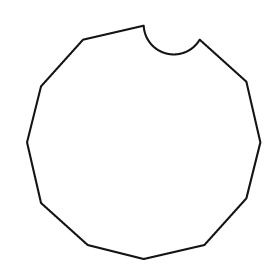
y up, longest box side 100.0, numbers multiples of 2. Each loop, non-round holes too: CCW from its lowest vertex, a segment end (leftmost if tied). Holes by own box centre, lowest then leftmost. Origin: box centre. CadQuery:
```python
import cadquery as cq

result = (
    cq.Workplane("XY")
    .moveTo(0.0, -50.0)
    .lineTo(26.0, -44.0)
    .lineTo(44.0, -24.0)
    .lineTo(50.0, 0.0)
    .lineTo(44.0, 26.0)
    .lineTo(24.0, 44.0)
    .threePointArc((10.0, 38.0), (0.0, 50.0))
    .lineTo(-26.0, 44.0)
    .lineTo(-44.0, 24.0)
    .lineTo(-50.0, 0.0)
    .lineTo(-44.0, -26.0)
    .lineTo(-24.0, -44.0)
    .close()
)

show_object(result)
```